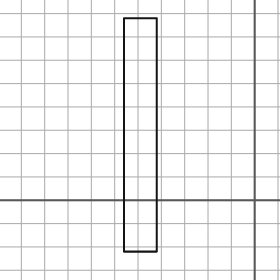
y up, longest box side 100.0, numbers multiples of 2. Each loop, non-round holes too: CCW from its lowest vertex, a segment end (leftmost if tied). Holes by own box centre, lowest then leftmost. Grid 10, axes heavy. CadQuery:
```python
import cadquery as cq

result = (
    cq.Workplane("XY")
    .moveTo(-56.0, -22.0)
    .lineTo(-42.0, -22.0)
    .lineTo(-42.0, 78.0)
    .lineTo(-56.0, 78.0)
    .close()
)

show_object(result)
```